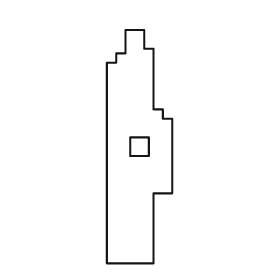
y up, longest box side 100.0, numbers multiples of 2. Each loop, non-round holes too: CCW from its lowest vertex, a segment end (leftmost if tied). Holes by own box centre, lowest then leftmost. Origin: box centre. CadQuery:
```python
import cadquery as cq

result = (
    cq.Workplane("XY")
    .moveTo(-14.0, -50.0)
    .lineTo(6.0, -50.0)
    .lineTo(6.0, -20.0)
    .lineTo(14.0, -20.0)
    .lineTo(14.0, 12.0)
    .lineTo(10.0, 12.0)
    .lineTo(10.0, 16.0)
    .lineTo(6.0, 16.0)
    .lineTo(6.0, 42.0)
    .lineTo(2.0, 42.0)
    .lineTo(2.0, 50.0)
    .lineTo(-6.0, 50.0)
    .lineTo(-6.0, 40.0)
    .lineTo(-10.0, 40.0)
    .lineTo(-10.0, 36.0)
    .lineTo(-14.0, 36.0)
    .close()
    .moveTo(-4.0, -4.0)
    .lineTo(4.0, -4.0)
    .lineTo(4.0, 4.0)
    .lineTo(-4.0, 4.0)
    .close()
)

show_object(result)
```